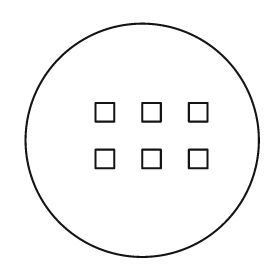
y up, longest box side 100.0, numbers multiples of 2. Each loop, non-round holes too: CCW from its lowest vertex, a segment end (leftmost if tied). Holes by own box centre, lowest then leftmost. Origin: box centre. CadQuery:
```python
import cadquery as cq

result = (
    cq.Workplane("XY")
    .moveTo(0.0, 0.0)
    .circle(50.0)
    .moveTo(-20.0, -12.0)
    .lineTo(-12.0, -12.0)
    .lineTo(-12.0, -4.0)
    .lineTo(-20.0, -4.0)
    .close()
    .moveTo(0.0, -12.0)
    .lineTo(8.0, -12.0)
    .lineTo(8.0, -4.0)
    .lineTo(0.0, -4.0)
    .close()
    .moveTo(20.0, -12.0)
    .lineTo(28.0, -12.0)
    .lineTo(28.0, -4.0)
    .lineTo(20.0, -4.0)
    .close()
    .moveTo(-20.0, 8.0)
    .lineTo(-12.0, 8.0)
    .lineTo(-12.0, 16.0)
    .lineTo(-20.0, 16.0)
    .close()
    .moveTo(0.0, 8.0)
    .lineTo(8.0, 8.0)
    .lineTo(8.0, 16.0)
    .lineTo(0.0, 16.0)
    .close()
    .moveTo(20.0, 8.0)
    .lineTo(28.0, 8.0)
    .lineTo(28.0, 16.0)
    .lineTo(20.0, 16.0)
    .close()
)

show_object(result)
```